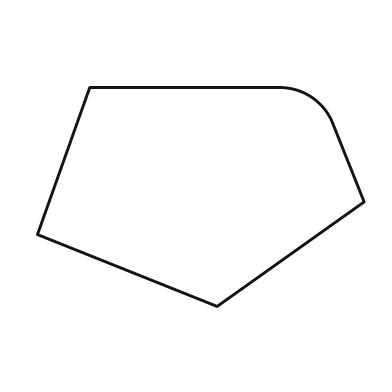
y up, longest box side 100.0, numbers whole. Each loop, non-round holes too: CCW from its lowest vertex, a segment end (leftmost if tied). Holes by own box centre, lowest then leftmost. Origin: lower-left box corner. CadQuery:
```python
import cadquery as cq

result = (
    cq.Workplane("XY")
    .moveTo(55.0, 0.0)
    .lineTo(100.0, 32.0)
    .lineTo(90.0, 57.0)
    .threePointArc((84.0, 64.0), (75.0, 67.0))
    .lineTo(16.0, 67.0)
    .lineTo(0.0, 22.0)
    .close()
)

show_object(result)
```